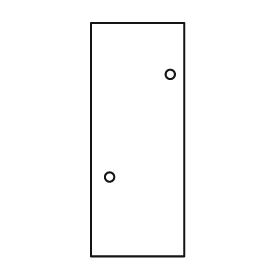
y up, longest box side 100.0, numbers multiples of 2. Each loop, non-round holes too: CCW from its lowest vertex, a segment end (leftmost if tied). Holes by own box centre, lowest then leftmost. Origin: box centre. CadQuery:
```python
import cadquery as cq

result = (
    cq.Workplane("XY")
    .moveTo(-20.0, -50.0)
    .lineTo(20.0, -50.0)
    .lineTo(20.0, 50.0)
    .lineTo(-20.0, 50.0)
    .close()
    .moveTo(-12.0, -16.0)
    .circle(2.0)
    .moveTo(14.0, 28.0)
    .circle(2.0)
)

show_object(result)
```